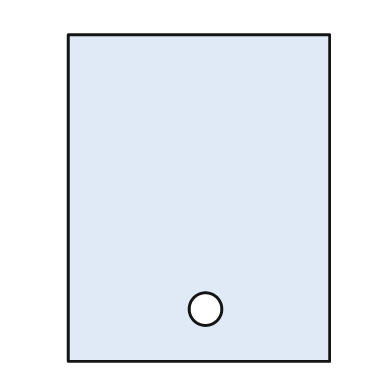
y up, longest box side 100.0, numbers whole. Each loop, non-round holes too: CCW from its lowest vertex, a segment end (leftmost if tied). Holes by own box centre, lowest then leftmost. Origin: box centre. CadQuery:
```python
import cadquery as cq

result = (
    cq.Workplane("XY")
    .moveTo(-40.0, -50.0)
    .lineTo(40.0, -50.0)
    .lineTo(40.0, 50.0)
    .lineTo(-40.0, 50.0)
    .close()
    .moveTo(2.0, -34.0)
    .circle(5.0)
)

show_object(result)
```